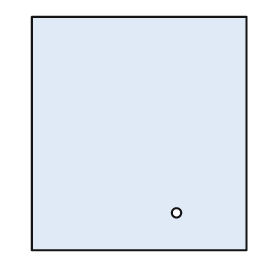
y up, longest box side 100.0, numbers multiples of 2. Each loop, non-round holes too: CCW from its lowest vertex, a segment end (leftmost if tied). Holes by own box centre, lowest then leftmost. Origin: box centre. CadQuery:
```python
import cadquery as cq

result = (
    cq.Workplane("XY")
    .moveTo(-46.0, -50.0)
    .lineTo(46.0, -50.0)
    .lineTo(46.0, 50.0)
    .lineTo(-46.0, 50.0)
    .close()
    .moveTo(16.0, -34.0)
    .circle(2.0)
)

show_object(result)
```